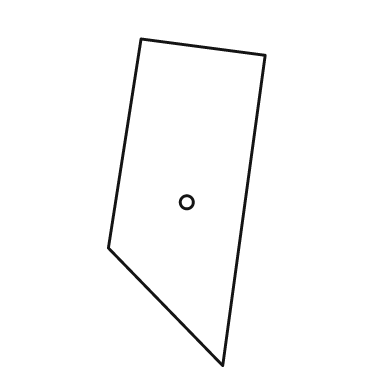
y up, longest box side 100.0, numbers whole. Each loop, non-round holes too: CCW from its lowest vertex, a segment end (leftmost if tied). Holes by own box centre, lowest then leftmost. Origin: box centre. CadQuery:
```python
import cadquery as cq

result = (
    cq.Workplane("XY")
    .moveTo(11.0, -50.0)
    .lineTo(24.0, 45.0)
    .lineTo(-14.0, 50.0)
    .lineTo(-24.0, -14.0)
    .close()
    .moveTo(0.0, 0.0)
    .circle(2.0)
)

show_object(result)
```